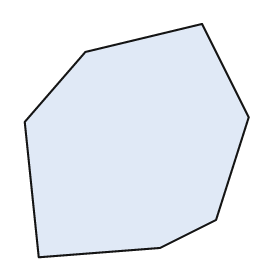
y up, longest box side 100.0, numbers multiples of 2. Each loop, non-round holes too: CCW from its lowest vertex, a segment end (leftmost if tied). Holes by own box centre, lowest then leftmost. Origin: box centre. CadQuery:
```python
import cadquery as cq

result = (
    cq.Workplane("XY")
    .moveTo(-42.0, -50.0)
    .lineTo(10.0, -46.0)
    .lineTo(34.0, -34.0)
    .lineTo(48.0, 10.0)
    .lineTo(28.0, 50.0)
    .lineTo(-22.0, 38.0)
    .lineTo(-48.0, 8.0)
    .close()
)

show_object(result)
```